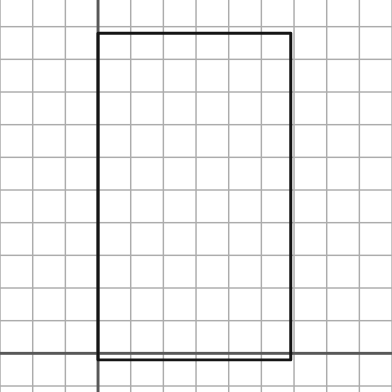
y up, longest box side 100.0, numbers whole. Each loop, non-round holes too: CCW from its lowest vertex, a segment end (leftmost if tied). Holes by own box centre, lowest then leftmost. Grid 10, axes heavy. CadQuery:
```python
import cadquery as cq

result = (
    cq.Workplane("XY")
    .moveTo(0.0, -2.0)
    .lineTo(59.0, -2.0)
    .lineTo(59.0, 98.0)
    .lineTo(0.0, 98.0)
    .close()
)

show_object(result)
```